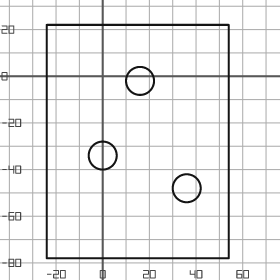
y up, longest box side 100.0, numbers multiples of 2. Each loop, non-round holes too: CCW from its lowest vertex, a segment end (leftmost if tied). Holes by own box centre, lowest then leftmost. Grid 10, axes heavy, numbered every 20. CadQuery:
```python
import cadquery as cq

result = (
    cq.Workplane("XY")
    .moveTo(-24.0, -78.0)
    .lineTo(54.0, -78.0)
    .lineTo(54.0, 22.0)
    .lineTo(-24.0, 22.0)
    .close()
    .moveTo(36.0, -48.0)
    .circle(6.0)
    .moveTo(0.0, -34.0)
    .circle(6.0)
    .moveTo(16.0, -2.0)
    .circle(6.0)
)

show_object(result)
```